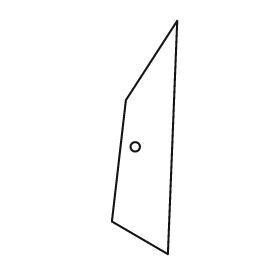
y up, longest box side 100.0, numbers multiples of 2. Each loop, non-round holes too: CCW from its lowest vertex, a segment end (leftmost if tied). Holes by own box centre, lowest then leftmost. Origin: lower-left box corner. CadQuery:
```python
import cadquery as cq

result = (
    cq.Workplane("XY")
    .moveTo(24.0, 0.0)
    .lineTo(28.0, 100.0)
    .lineTo(6.0, 66.0)
    .lineTo(0.0, 14.0)
    .close()
    .moveTo(10.0, 46.0)
    .circle(2.0)
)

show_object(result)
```